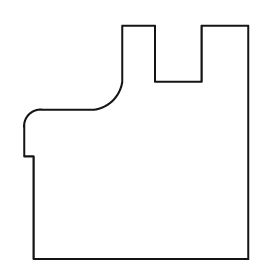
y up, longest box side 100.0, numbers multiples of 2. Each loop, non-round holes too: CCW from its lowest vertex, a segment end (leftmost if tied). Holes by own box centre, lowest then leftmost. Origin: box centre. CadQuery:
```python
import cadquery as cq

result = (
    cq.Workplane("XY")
    .moveTo(-44.0, -50.0)
    .lineTo(48.0, -50.0)
    .lineTo(48.0, 50.0)
    .lineTo(28.0, 50.0)
    .lineTo(28.0, 26.0)
    .lineTo(8.0, 26.0)
    .lineTo(8.0, 50.0)
    .lineTo(-6.0, 50.0)
    .lineTo(-6.0, 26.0)
    .threePointArc((-10.0, 18.0), (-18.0, 14.0))
    .lineTo(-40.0, 14.0)
    .threePointArc((-46.0, 12.0), (-48.0, 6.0))
    .lineTo(-48.0, -6.0)
    .lineTo(-44.0, -6.0)
    .close()
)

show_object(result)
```